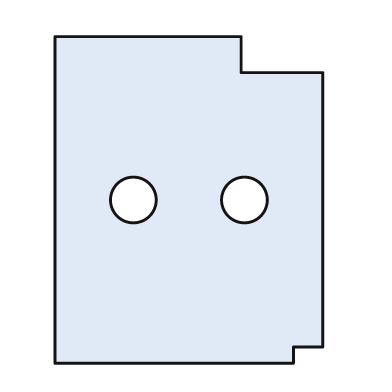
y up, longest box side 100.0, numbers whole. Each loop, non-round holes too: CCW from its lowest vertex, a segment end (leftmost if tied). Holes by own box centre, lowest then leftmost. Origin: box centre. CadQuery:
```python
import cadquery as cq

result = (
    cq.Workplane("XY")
    .moveTo(-41.0, -50.0)
    .lineTo(32.0, -50.0)
    .lineTo(32.0, -45.0)
    .lineTo(41.0, -45.0)
    .lineTo(41.0, 39.0)
    .lineTo(16.0, 39.0)
    .lineTo(16.0, 50.0)
    .lineTo(-41.0, 50.0)
    .close()
    .moveTo(-17.0, 0.0)
    .circle(7.0)
    .moveTo(17.0, 0.0)
    .circle(7.0)
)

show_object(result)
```